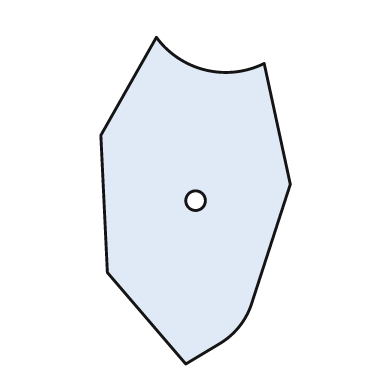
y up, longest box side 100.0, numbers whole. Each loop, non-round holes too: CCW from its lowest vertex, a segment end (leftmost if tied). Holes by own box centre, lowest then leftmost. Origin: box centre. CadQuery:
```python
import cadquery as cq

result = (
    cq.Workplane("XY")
    .moveTo(-3.0, -50.0)
    .lineTo(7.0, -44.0)
    .threePointArc((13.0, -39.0), (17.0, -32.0))
    .lineTo(29.0, 5.0)
    .lineTo(21.0, 42.0)
    .threePointArc((3.0, 40.0), (-12.0, 50.0))
    .lineTo(-29.0, 20.0)
    .lineTo(-27.0, -22.0)
    .close()
    .moveTo(0.0, 0.0)
    .circle(3.0)
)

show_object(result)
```